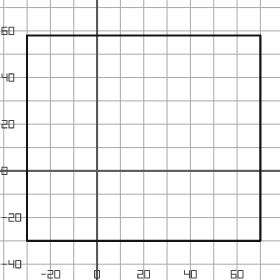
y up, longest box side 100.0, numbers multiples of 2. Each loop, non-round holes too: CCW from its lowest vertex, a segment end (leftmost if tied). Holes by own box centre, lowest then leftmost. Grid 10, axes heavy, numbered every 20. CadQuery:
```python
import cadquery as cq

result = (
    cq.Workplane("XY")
    .moveTo(-30.0, -30.0)
    .lineTo(70.0, -30.0)
    .lineTo(70.0, 58.0)
    .lineTo(-30.0, 58.0)
    .close()
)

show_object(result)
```